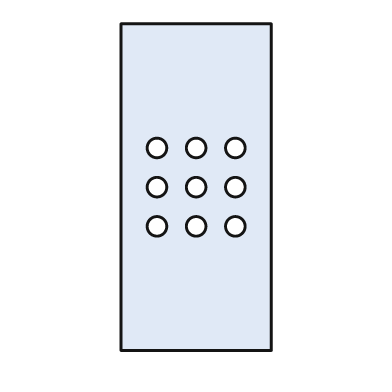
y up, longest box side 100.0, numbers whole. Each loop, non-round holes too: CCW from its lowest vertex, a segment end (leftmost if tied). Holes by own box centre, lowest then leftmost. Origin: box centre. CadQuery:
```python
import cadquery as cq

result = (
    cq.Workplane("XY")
    .moveTo(-23.0, -50.0)
    .lineTo(23.0, -50.0)
    .lineTo(23.0, 50.0)
    .lineTo(-23.0, 50.0)
    .close()
    .moveTo(-12.0, -12.0)
    .circle(3.0)
    .moveTo(0.0, -12.0)
    .circle(3.0)
    .moveTo(12.0, -12.0)
    .circle(3.0)
    .moveTo(-12.0, 0.0)
    .circle(3.0)
    .moveTo(0.0, 0.0)
    .circle(3.0)
    .moveTo(12.0, 0.0)
    .circle(3.0)
    .moveTo(-12.0, 12.0)
    .circle(3.0)
    .moveTo(0.0, 12.0)
    .circle(3.0)
    .moveTo(12.0, 12.0)
    .circle(3.0)
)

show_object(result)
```